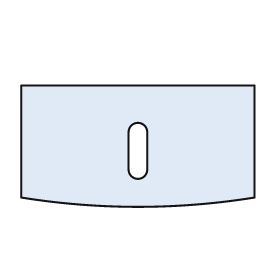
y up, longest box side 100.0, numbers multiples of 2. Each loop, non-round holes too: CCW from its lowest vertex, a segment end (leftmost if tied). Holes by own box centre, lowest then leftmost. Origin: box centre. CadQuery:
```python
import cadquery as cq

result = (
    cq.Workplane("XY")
    .moveTo(-50.0, -22.0)
    .threePointArc((0.0, -26.0), (50.0, -22.0))
    .lineTo(50.0, 26.0)
    .lineTo(-50.0, 26.0)
    .close()
    .moveTo(-4.0, -10.0)
    .threePointArc((0.0, -14.0), (4.0, -10.0))
    .lineTo(4.0, 6.0)
    .threePointArc((0.0, 10.0), (-4.0, 6.0))
    .close()
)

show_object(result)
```